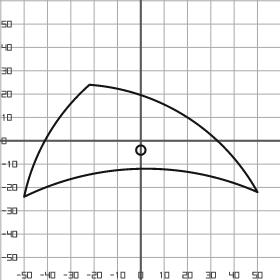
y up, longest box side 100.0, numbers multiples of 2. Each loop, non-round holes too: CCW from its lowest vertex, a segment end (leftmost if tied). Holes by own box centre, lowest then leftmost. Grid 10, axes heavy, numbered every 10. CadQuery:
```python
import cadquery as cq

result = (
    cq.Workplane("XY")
    .moveTo(-50.0, -24.0)
    .threePointArc((0.0, -12.0), (50.0, -22.0))
    .threePointArc((20.0, 10.0), (-22.0, 24.0))
    .threePointArc((-40.0, 2.0), (-50.0, -24.0))
    .close()
    .moveTo(0.0, -4.0)
    .circle(2.0)
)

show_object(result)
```